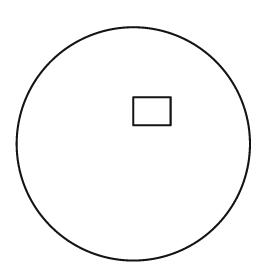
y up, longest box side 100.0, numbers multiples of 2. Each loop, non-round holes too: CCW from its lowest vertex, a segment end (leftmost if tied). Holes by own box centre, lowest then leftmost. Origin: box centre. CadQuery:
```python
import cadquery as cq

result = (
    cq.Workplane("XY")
    .moveTo(0.0, 0.0)
    .circle(50.0)
    .moveTo(0.0, 8.0)
    .lineTo(16.0, 8.0)
    .lineTo(16.0, 20.0)
    .lineTo(0.0, 20.0)
    .close()
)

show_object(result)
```